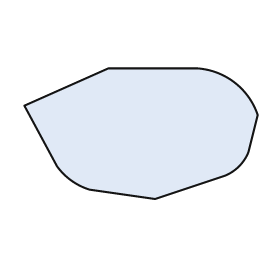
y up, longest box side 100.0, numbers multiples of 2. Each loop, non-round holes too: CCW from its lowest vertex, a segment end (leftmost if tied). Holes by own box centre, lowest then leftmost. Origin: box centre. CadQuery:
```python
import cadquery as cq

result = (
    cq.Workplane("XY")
    .moveTo(6.0, -28.0)
    .lineTo(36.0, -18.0)
    .threePointArc((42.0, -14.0), (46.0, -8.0))
    .lineTo(50.0, 8.0)
    .threePointArc((40.0, 22.0), (24.0, 28.0))
    .lineTo(-14.0, 28.0)
    .lineTo(-50.0, 12.0)
    .lineTo(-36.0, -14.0)
    .threePointArc((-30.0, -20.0), (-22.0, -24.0))
    .close()
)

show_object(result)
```